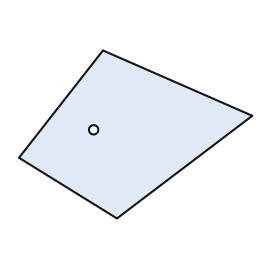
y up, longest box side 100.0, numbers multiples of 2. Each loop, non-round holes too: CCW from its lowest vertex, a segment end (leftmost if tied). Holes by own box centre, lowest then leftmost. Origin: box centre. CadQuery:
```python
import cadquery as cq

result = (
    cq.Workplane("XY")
    .moveTo(-8.0, -36.0)
    .lineTo(50.0, 8.0)
    .lineTo(-14.0, 36.0)
    .lineTo(-50.0, -10.0)
    .close()
    .moveTo(-18.0, 2.0)
    .circle(2.0)
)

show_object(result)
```